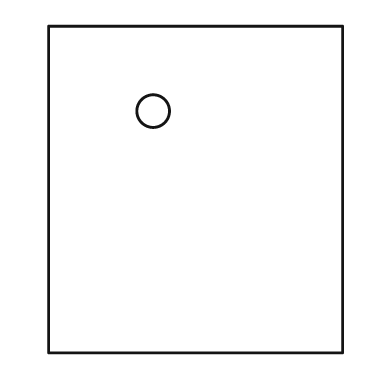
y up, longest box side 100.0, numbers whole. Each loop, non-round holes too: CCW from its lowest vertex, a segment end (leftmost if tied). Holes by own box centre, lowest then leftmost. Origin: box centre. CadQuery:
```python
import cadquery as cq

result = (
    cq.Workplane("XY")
    .moveTo(-45.0, -50.0)
    .lineTo(45.0, -50.0)
    .lineTo(45.0, 50.0)
    .lineTo(-45.0, 50.0)
    .close()
    .moveTo(-13.0, 24.0)
    .circle(5.0)
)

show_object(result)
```